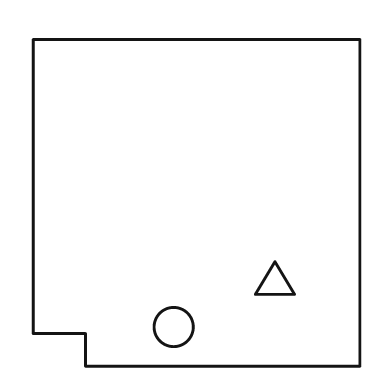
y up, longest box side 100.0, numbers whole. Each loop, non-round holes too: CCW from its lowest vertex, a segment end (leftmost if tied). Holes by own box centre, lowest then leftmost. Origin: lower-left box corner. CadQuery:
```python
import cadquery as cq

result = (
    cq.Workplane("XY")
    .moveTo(16.0, 0.0)
    .lineTo(100.0, 0.0)
    .lineTo(100.0, 100.0)
    .lineTo(0.0, 100.0)
    .lineTo(0.0, 10.0)
    .lineTo(16.0, 10.0)
    .close()
    .moveTo(43.0, 12.0)
    .circle(6.0)
    .moveTo(68.0, 22.0)
    .lineTo(80.0, 22.0)
    .lineTo(74.0, 32.0)
    .close()
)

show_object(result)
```